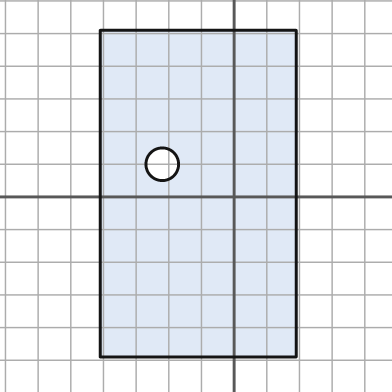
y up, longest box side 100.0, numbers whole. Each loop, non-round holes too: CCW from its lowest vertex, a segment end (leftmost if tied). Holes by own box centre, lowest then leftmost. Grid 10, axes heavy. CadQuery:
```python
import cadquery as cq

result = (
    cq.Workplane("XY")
    .moveTo(-41.0, -49.0)
    .lineTo(19.0, -49.0)
    .lineTo(19.0, 51.0)
    .lineTo(-41.0, 51.0)
    .close()
    .moveTo(-22.0, 10.0)
    .circle(5.0)
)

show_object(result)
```